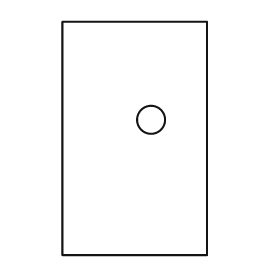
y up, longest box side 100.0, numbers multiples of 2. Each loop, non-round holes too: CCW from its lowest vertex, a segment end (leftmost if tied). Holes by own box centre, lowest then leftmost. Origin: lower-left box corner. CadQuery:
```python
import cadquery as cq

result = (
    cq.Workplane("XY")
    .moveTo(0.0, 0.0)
    .lineTo(62.0, 0.0)
    .lineTo(62.0, 100.0)
    .lineTo(0.0, 100.0)
    .close()
    .moveTo(38.0, 58.0)
    .circle(6.0)
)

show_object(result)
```